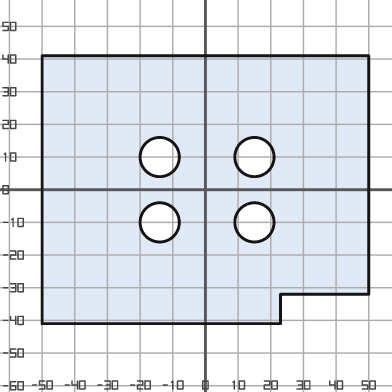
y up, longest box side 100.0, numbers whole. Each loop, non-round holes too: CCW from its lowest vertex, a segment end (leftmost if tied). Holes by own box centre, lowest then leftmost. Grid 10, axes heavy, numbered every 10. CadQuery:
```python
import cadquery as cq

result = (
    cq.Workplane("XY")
    .moveTo(-50.0, -41.0)
    .lineTo(23.0, -41.0)
    .lineTo(23.0, -32.0)
    .lineTo(50.0, -32.0)
    .lineTo(50.0, 41.0)
    .lineTo(-50.0, 41.0)
    .close()
    .moveTo(-14.0, -10.0)
    .circle(6.0)
    .moveTo(15.0, -10.0)
    .circle(6.0)
    .moveTo(-14.0, 10.0)
    .circle(6.0)
    .moveTo(15.0, 10.0)
    .circle(6.0)
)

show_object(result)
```